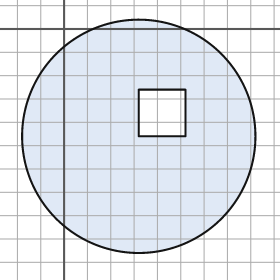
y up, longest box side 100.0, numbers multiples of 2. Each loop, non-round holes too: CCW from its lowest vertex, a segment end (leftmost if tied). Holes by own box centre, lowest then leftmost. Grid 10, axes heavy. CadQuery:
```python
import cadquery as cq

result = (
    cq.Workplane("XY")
    .moveTo(32.0, -46.0)
    .circle(50.0)
    .moveTo(32.0, -46.0)
    .lineTo(52.0, -46.0)
    .lineTo(52.0, -26.0)
    .lineTo(32.0, -26.0)
    .close()
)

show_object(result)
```